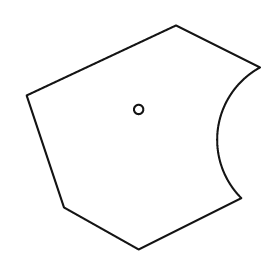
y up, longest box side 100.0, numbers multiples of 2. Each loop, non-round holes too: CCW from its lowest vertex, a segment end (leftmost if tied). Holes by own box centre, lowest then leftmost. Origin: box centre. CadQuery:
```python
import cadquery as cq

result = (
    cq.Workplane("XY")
    .moveTo(-2.0, -48.0)
    .lineTo(42.0, -26.0)
    .threePointArc((32.0, 4.0), (50.0, 30.0))
    .lineTo(14.0, 48.0)
    .lineTo(-50.0, 18.0)
    .lineTo(-34.0, -30.0)
    .close()
    .moveTo(-2.0, 12.0)
    .circle(2.0)
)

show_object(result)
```